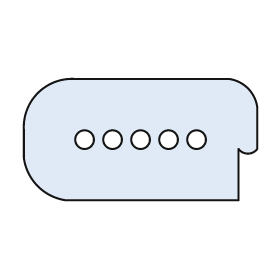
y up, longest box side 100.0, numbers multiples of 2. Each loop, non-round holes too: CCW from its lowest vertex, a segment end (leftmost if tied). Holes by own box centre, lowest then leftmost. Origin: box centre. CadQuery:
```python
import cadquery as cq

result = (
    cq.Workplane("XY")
    .moveTo(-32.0, -26.0)
    .lineTo(42.0, -26.0)
    .lineTo(42.0, -4.0)
    .threePointArc((46.0, -6.0), (50.0, -4.0))
    .lineTo(50.0, 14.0)
    .threePointArc((46.0, 22.0), (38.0, 26.0))
    .lineTo(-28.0, 26.0)
    .threePointArc((-44.0, 20.0), (-50.0, 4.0))
    .lineTo(-50.0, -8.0)
    .threePointArc((-44.0, -20.0), (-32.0, -26.0))
    .close()
    .moveTo(-24.0, 0.0)
    .circle(4.0)
    .moveTo(-12.0, 0.0)
    .circle(4.0)
    .moveTo(0.0, 0.0)
    .circle(4.0)
    .moveTo(12.0, 0.0)
    .circle(4.0)
    .moveTo(24.0, 0.0)
    .circle(4.0)
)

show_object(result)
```